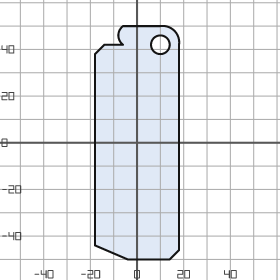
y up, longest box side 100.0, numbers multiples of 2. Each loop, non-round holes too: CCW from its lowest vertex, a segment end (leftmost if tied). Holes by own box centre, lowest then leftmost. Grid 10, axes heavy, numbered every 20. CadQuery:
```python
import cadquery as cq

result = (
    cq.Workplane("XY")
    .moveTo(-4.0, -50.0)
    .lineTo(14.0, -50.0)
    .lineTo(18.0, -46.0)
    .lineTo(18.0, 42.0)
    .threePointArc((16.0, 48.0), (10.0, 50.0))
    .lineTo(-6.0, 50.0)
    .threePointArc((-8.0, 46.0), (-6.0, 42.0))
    .lineTo(-14.0, 42.0)
    .lineTo(-18.0, 38.0)
    .lineTo(-18.0, -44.0)
    .close()
    .moveTo(10.0, 42.0)
    .circle(4.0)
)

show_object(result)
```